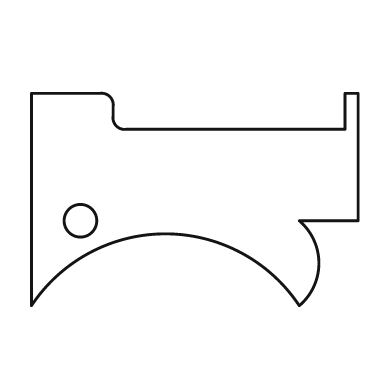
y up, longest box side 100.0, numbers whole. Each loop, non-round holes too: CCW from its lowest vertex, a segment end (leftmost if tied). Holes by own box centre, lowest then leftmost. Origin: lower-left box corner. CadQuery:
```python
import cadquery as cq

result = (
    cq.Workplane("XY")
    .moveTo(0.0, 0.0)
    .threePointArc((41.0, 22.0), (82.0, 0.0))
    .threePointArc((88.0, 13.0), (82.0, 26.0))
    .lineTo(100.0, 26.0)
    .lineTo(100.0, 65.0)
    .lineTo(96.0, 65.0)
    .lineTo(96.0, 54.0)
    .lineTo(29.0, 54.0)
    .threePointArc((26.0, 55.0), (25.0, 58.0))
    .lineTo(25.0, 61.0)
    .threePointArc((24.0, 64.0), (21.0, 65.0))
    .lineTo(0.0, 65.0)
    .close()
    .moveTo(15.0, 26.0)
    .circle(5.0)
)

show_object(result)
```